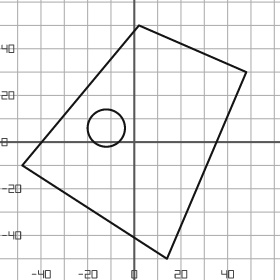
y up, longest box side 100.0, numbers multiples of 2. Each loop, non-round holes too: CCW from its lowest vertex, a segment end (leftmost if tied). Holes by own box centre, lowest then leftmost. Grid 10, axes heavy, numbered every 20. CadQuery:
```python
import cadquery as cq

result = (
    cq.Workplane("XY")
    .moveTo(14.0, -50.0)
    .lineTo(48.0, 30.0)
    .lineTo(2.0, 50.0)
    .lineTo(-48.0, -10.0)
    .close()
    .moveTo(-12.0, 6.0)
    .circle(8.0)
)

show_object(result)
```